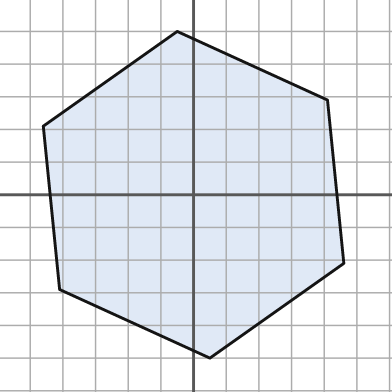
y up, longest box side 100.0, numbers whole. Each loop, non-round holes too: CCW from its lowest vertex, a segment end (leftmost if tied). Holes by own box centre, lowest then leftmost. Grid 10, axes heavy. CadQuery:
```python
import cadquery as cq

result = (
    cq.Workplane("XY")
    .moveTo(5.0, -50.0)
    .lineTo(46.0, -21.0)
    .lineTo(41.0, 29.0)
    .lineTo(-5.0, 50.0)
    .lineTo(-46.0, 21.0)
    .lineTo(-41.0, -29.0)
    .close()
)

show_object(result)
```